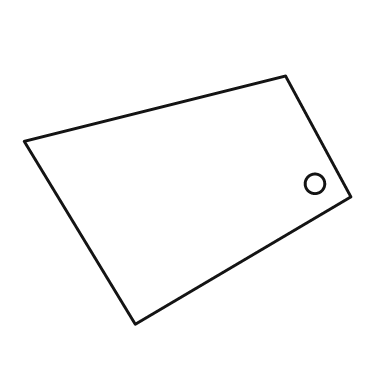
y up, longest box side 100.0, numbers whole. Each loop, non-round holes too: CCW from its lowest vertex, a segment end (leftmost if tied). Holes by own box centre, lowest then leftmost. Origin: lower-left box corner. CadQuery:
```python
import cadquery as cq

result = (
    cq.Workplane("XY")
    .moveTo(34.0, 0.0)
    .lineTo(100.0, 39.0)
    .lineTo(80.0, 76.0)
    .lineTo(0.0, 56.0)
    .close()
    .moveTo(89.0, 43.0)
    .circle(3.0)
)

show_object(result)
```